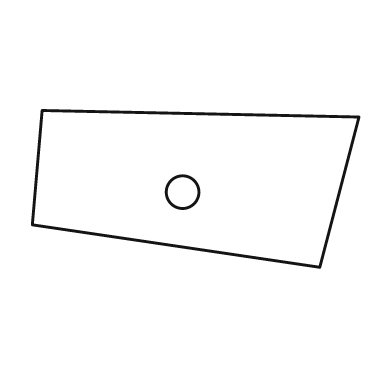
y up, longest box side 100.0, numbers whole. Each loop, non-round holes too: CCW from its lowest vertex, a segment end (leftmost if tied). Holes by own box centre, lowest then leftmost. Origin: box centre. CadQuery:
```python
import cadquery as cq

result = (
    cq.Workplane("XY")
    .moveTo(38.0, -24.0)
    .lineTo(50.0, 22.0)
    .lineTo(-47.0, 24.0)
    .lineTo(-50.0, -11.0)
    .close()
    .moveTo(-4.0, -1.0)
    .circle(5.0)
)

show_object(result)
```